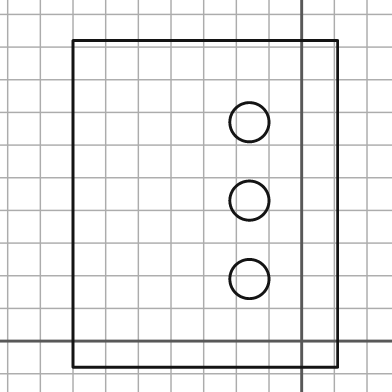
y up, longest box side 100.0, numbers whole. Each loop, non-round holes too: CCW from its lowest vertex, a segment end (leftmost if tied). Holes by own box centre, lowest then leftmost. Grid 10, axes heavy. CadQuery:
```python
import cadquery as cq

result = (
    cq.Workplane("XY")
    .moveTo(-70.0, -8.0)
    .lineTo(11.0, -8.0)
    .lineTo(11.0, 92.0)
    .lineTo(-70.0, 92.0)
    .close()
    .moveTo(-16.0, 19.0)
    .circle(6.0)
    .moveTo(-16.0, 43.0)
    .circle(6.0)
    .moveTo(-16.0, 67.0)
    .circle(6.0)
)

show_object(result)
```